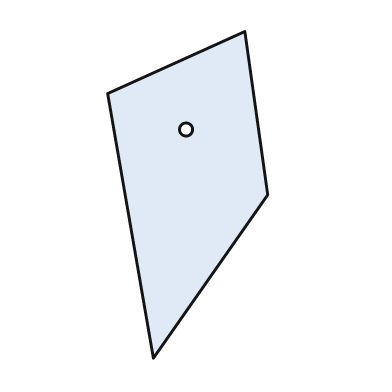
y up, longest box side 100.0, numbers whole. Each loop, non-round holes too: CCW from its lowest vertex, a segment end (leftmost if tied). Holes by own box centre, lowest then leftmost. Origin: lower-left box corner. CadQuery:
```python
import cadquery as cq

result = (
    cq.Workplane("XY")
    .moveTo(14.0, 0.0)
    .lineTo(49.0, 50.0)
    .lineTo(42.0, 100.0)
    .lineTo(0.0, 81.0)
    .close()
    .moveTo(24.0, 70.0)
    .circle(2.0)
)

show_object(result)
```